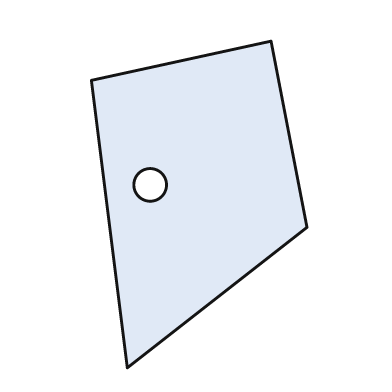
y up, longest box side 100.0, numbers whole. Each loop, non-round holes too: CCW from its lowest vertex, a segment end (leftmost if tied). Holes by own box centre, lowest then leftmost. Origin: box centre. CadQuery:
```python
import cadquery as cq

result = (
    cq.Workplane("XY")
    .moveTo(-22.0, -50.0)
    .lineTo(33.0, -7.0)
    .lineTo(22.0, 50.0)
    .lineTo(-33.0, 38.0)
    .close()
    .moveTo(-15.0, 6.0)
    .circle(5.0)
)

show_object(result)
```